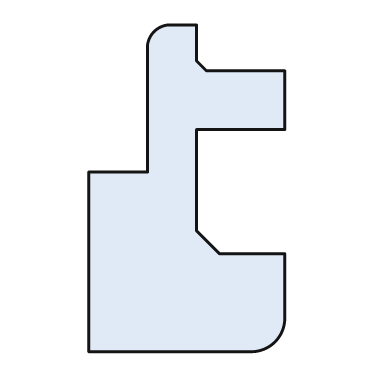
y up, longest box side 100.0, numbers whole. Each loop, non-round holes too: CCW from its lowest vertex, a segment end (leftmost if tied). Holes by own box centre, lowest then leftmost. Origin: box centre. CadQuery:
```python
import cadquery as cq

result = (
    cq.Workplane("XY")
    .moveTo(-30.0, -50.0)
    .lineTo(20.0, -50.0)
    .threePointArc((27.0, -47.0), (30.0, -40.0))
    .lineTo(30.0, -20.0)
    .lineTo(10.0, -20.0)
    .lineTo(3.0, -13.0)
    .lineTo(3.0, 18.0)
    .lineTo(30.0, 18.0)
    .lineTo(30.0, 36.0)
    .lineTo(6.0, 36.0)
    .lineTo(3.0, 39.0)
    .lineTo(3.0, 50.0)
    .lineTo(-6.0, 50.0)
    .threePointArc((-10.0, 48.0), (-12.0, 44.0))
    .lineTo(-12.0, 5.0)
    .lineTo(-30.0, 5.0)
    .close()
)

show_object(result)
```